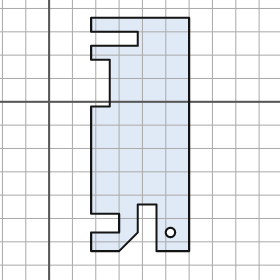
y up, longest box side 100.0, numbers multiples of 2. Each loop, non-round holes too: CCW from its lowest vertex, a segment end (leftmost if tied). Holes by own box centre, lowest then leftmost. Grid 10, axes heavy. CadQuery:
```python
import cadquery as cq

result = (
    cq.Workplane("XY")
    .moveTo(18.0, -64.0)
    .lineTo(30.0, -64.0)
    .lineTo(38.0, -56.0)
    .lineTo(38.0, -44.0)
    .lineTo(46.0, -44.0)
    .lineTo(46.0, -64.0)
    .lineTo(60.0, -64.0)
    .lineTo(60.0, 36.0)
    .lineTo(18.0, 36.0)
    .lineTo(18.0, 30.0)
    .lineTo(38.0, 30.0)
    .lineTo(38.0, 24.0)
    .lineTo(18.0, 24.0)
    .lineTo(18.0, 18.0)
    .lineTo(26.0, 18.0)
    .lineTo(26.0, -2.0)
    .lineTo(18.0, -2.0)
    .lineTo(18.0, -48.0)
    .lineTo(30.0, -48.0)
    .lineTo(30.0, -56.0)
    .lineTo(18.0, -56.0)
    .close()
    .moveTo(52.0, -56.0)
    .circle(2.0)
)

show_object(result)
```